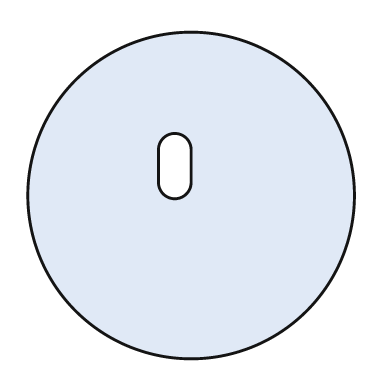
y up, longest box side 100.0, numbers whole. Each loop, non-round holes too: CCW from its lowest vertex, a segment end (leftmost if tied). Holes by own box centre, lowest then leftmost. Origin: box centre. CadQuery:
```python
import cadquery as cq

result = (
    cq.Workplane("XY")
    .moveTo(0.0, 0.0)
    .circle(50.0)
    .moveTo(-10.0, 4.0)
    .threePointArc((-5.0, -1.0), (0.0, 4.0))
    .lineTo(0.0, 14.0)
    .threePointArc((-5.0, 19.0), (-10.0, 14.0))
    .close()
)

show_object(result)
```